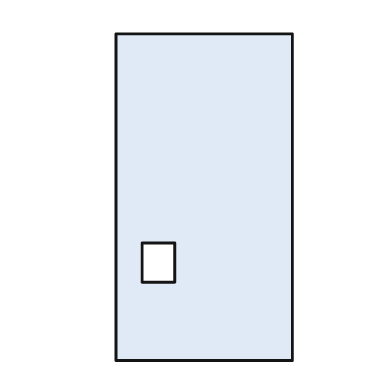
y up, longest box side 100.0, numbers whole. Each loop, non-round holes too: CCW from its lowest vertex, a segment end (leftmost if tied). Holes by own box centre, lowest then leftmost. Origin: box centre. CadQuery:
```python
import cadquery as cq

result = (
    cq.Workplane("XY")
    .moveTo(-27.0, -50.0)
    .lineTo(27.0, -50.0)
    .lineTo(27.0, 50.0)
    .lineTo(-27.0, 50.0)
    .close()
    .moveTo(-19.0, -26.0)
    .lineTo(-9.0, -26.0)
    .lineTo(-9.0, -14.0)
    .lineTo(-19.0, -14.0)
    .close()
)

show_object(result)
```